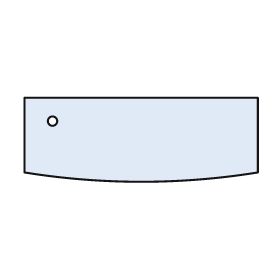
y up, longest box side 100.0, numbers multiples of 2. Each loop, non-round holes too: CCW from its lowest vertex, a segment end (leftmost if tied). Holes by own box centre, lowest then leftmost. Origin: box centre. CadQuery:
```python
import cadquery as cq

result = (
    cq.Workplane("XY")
    .moveTo(-50.0, -14.0)
    .threePointArc((0.0, -18.0), (50.0, -14.0))
    .lineTo(50.0, 18.0)
    .lineTo(-50.0, 18.0)
    .close()
    .moveTo(-38.0, 8.0)
    .circle(2.0)
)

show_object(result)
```